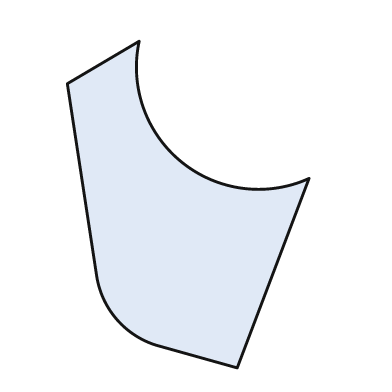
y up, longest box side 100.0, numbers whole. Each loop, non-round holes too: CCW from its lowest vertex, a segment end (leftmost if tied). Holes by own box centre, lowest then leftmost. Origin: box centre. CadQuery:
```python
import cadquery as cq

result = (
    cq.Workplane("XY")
    .moveTo(15.0, -50.0)
    .lineTo(37.0, 8.0)
    .threePointArc((-2.0, 13.0), (-15.0, 50.0))
    .lineTo(-37.0, 37.0)
    .lineTo(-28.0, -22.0)
    .threePointArc((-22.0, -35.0), (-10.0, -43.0))
    .close()
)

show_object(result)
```